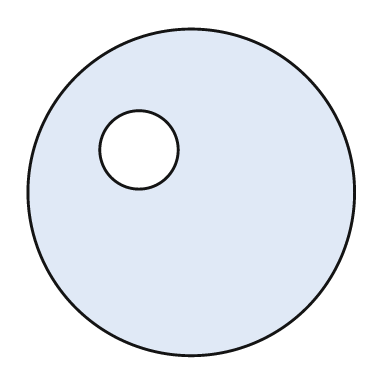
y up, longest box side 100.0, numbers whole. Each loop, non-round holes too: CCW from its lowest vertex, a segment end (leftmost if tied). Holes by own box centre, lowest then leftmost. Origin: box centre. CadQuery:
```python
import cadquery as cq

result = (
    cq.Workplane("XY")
    .moveTo(0.0, 0.0)
    .circle(50.0)
    .moveTo(-16.0, 13.0)
    .circle(12.0)
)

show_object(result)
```